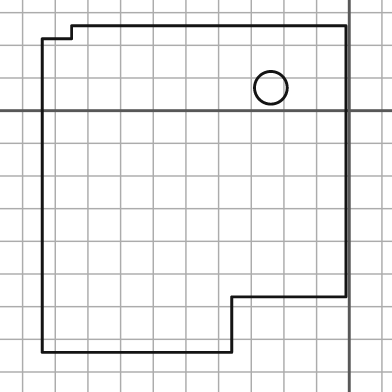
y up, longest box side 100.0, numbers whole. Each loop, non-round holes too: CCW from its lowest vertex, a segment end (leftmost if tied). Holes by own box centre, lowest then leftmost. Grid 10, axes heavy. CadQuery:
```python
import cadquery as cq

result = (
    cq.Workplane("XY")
    .moveTo(-94.0, -74.0)
    .lineTo(-36.0, -74.0)
    .lineTo(-36.0, -57.0)
    .lineTo(-1.0, -57.0)
    .lineTo(-1.0, 26.0)
    .lineTo(-85.0, 26.0)
    .lineTo(-85.0, 22.0)
    .lineTo(-94.0, 22.0)
    .close()
    .moveTo(-24.0, 7.0)
    .circle(5.0)
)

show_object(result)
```